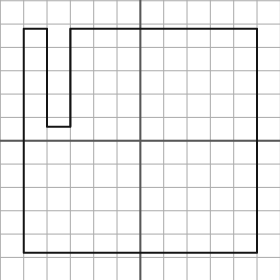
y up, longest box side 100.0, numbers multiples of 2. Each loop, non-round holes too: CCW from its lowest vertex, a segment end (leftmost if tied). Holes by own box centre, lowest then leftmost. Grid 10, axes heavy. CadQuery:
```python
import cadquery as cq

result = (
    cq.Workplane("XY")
    .moveTo(-50.0, -48.0)
    .lineTo(50.0, -48.0)
    .lineTo(50.0, 48.0)
    .lineTo(-30.0, 48.0)
    .lineTo(-30.0, 6.0)
    .lineTo(-40.0, 6.0)
    .lineTo(-40.0, 48.0)
    .lineTo(-50.0, 48.0)
    .close()
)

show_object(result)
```